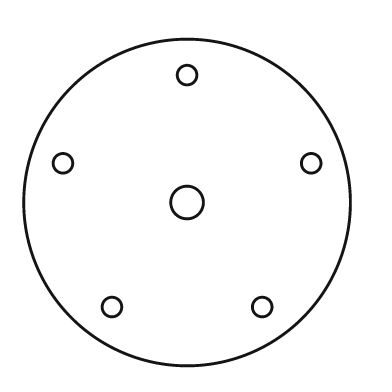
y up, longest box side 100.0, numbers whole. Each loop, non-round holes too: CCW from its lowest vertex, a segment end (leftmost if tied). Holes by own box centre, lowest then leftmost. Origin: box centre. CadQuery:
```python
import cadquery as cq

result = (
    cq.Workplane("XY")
    .moveTo(0.0, 0.0)
    .circle(50.0)
    .moveTo(-23.0, -32.0)
    .circle(3.0)
    .moveTo(23.0, -32.0)
    .circle(3.0)
    .moveTo(0.0, 0.0)
    .circle(5.0)
    .moveTo(-38.0, 12.0)
    .circle(3.0)
    .moveTo(38.0, 12.0)
    .circle(3.0)
    .moveTo(0.0, 39.0)
    .circle(3.0)
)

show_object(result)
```